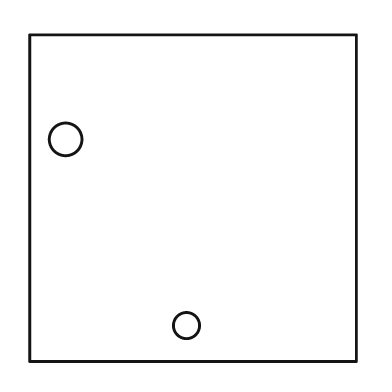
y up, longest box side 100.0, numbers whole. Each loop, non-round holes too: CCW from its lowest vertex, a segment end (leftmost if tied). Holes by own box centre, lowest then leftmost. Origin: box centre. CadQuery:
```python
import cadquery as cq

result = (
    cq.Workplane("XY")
    .moveTo(-50.0, -50.0)
    .lineTo(50.0, -50.0)
    .lineTo(50.0, 50.0)
    .lineTo(-50.0, 50.0)
    .close()
    .moveTo(-2.0, -39.0)
    .circle(4.0)
    .moveTo(-39.0, 18.0)
    .circle(5.0)
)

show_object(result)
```